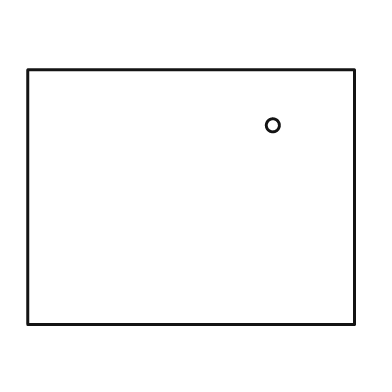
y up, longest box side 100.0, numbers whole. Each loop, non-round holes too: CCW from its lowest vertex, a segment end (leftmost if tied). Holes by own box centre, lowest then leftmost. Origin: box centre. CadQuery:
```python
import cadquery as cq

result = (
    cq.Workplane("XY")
    .moveTo(-50.0, -39.0)
    .lineTo(50.0, -39.0)
    .lineTo(50.0, 39.0)
    .lineTo(-50.0, 39.0)
    .close()
    .moveTo(25.0, 22.0)
    .circle(2.0)
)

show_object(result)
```